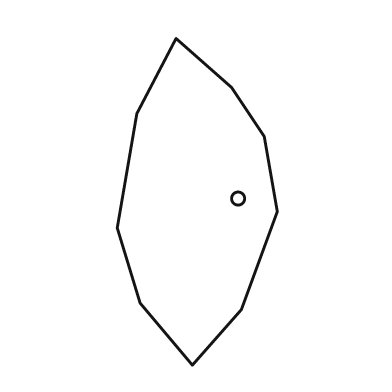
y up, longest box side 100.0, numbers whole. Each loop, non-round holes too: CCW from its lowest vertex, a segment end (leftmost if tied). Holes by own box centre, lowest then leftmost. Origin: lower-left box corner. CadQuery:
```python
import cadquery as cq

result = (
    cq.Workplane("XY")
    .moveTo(23.0, 0.0)
    .lineTo(38.0, 17.0)
    .lineTo(49.0, 47.0)
    .lineTo(45.0, 70.0)
    .lineTo(35.0, 85.0)
    .lineTo(18.0, 100.0)
    .lineTo(6.0, 77.0)
    .lineTo(0.0, 42.0)
    .lineTo(7.0, 19.0)
    .close()
    .moveTo(37.0, 51.0)
    .circle(2.0)
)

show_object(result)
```